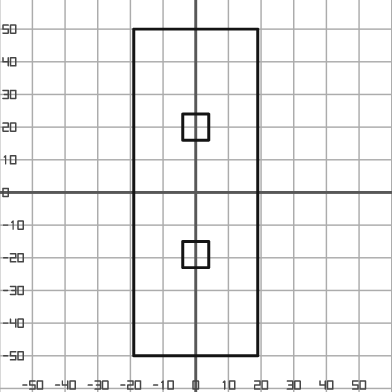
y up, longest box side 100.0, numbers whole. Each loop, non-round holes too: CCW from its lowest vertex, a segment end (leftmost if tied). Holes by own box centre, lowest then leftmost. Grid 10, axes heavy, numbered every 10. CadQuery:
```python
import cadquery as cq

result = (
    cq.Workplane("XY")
    .moveTo(-19.0, -50.0)
    .lineTo(19.0, -50.0)
    .lineTo(19.0, 50.0)
    .lineTo(-19.0, 50.0)
    .close()
    .moveTo(-4.0, -23.0)
    .lineTo(4.0, -23.0)
    .lineTo(4.0, -15.0)
    .lineTo(-4.0, -15.0)
    .close()
    .moveTo(-4.0, 16.0)
    .lineTo(4.0, 16.0)
    .lineTo(4.0, 24.0)
    .lineTo(-4.0, 24.0)
    .close()
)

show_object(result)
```